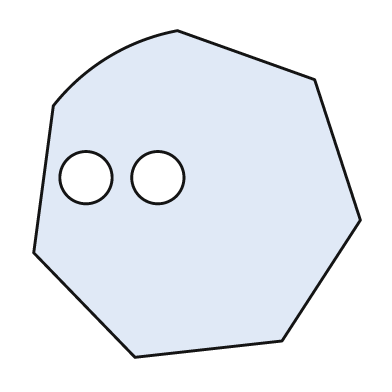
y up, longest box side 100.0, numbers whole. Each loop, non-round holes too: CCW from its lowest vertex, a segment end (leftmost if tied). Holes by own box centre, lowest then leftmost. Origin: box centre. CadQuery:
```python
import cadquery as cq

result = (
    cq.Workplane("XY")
    .moveTo(-19.0, -50.0)
    .lineTo(26.0, -45.0)
    .lineTo(50.0, -8.0)
    .lineTo(36.0, 35.0)
    .lineTo(-6.0, 50.0)
    .threePointArc((-27.0, 42.0), (-44.0, 27.0))
    .lineTo(-50.0, -18.0)
    .close()
    .moveTo(-34.0, 5.0)
    .circle(8.0)
    .moveTo(-12.0, 5.0)
    .circle(8.0)
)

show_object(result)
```